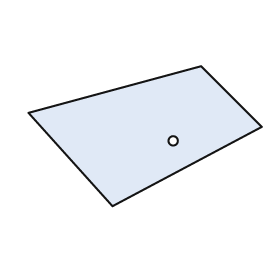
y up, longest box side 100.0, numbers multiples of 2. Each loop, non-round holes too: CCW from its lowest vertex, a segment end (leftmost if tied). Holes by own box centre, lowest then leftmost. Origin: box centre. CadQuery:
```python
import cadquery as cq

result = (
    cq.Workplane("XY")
    .moveTo(-14.0, -30.0)
    .lineTo(50.0, 4.0)
    .lineTo(24.0, 30.0)
    .lineTo(-50.0, 10.0)
    .close()
    .moveTo(12.0, -2.0)
    .circle(2.0)
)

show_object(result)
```